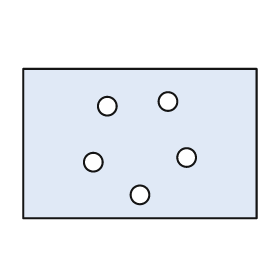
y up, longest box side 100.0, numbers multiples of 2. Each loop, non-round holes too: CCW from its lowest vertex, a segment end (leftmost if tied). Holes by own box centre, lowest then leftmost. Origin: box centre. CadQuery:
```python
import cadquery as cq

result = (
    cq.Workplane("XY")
    .moveTo(-50.0, -32.0)
    .lineTo(50.0, -32.0)
    .lineTo(50.0, 32.0)
    .lineTo(-50.0, 32.0)
    .close()
    .moveTo(0.0, -22.0)
    .circle(4.0)
    .moveTo(-20.0, -8.0)
    .circle(4.0)
    .moveTo(20.0, -6.0)
    .circle(4.0)
    .moveTo(-14.0, 16.0)
    .circle(4.0)
    .moveTo(12.0, 18.0)
    .circle(4.0)
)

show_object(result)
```